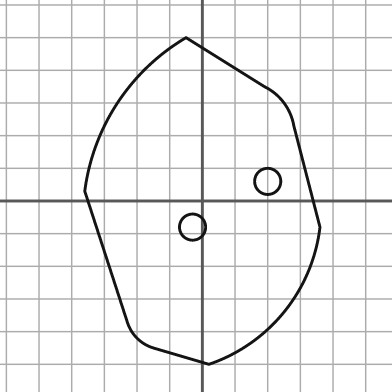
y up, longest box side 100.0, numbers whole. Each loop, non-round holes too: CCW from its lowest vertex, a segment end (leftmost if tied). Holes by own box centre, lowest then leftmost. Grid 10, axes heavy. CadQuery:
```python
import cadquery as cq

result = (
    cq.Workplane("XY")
    .moveTo(2.0, -50.0)
    .threePointArc((25.0, -34.0), (36.0, -8.0))
    .lineTo(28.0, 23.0)
    .threePointArc((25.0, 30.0), (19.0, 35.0))
    .lineTo(-5.0, 50.0)
    .threePointArc((-26.0, 30.0), (-36.0, 3.0))
    .lineTo(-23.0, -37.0)
    .threePointArc((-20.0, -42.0), (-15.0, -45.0))
    .close()
    .moveTo(-3.0, -8.0)
    .circle(4.0)
    .moveTo(20.0, 6.0)
    .circle(4.0)
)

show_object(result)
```